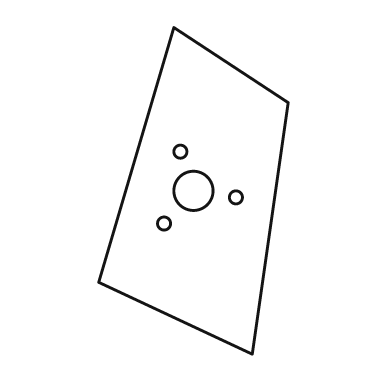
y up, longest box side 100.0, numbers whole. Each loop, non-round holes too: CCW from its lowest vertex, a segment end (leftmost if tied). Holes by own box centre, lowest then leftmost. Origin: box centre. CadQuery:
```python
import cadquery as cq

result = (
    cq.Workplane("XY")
    .moveTo(18.0, -50.0)
    .lineTo(29.0, 27.0)
    .lineTo(-6.0, 50.0)
    .lineTo(-29.0, -28.0)
    .close()
    .moveTo(-9.0, -10.0)
    .circle(2.0)
    .moveTo(13.0, -2.0)
    .circle(2.0)
    .moveTo(0.0, 0.0)
    .circle(6.0)
    .moveTo(-4.0, 12.0)
    .circle(2.0)
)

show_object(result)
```